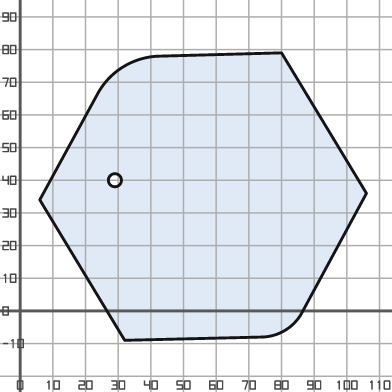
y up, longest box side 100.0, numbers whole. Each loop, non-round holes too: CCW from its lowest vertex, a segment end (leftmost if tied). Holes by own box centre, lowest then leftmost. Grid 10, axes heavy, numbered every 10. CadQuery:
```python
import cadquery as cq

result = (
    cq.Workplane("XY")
    .moveTo(32.0, -9.0)
    .lineTo(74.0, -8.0)
    .threePointArc((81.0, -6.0), (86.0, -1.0))
    .lineTo(106.0, 36.0)
    .lineTo(80.0, 79.0)
    .lineTo(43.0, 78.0)
    .threePointArc((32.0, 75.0), (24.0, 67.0))
    .lineTo(6.0, 34.0)
    .close()
    .moveTo(29.0, 40.0)
    .circle(2.0)
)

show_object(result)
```